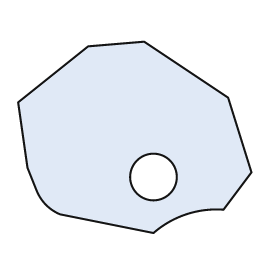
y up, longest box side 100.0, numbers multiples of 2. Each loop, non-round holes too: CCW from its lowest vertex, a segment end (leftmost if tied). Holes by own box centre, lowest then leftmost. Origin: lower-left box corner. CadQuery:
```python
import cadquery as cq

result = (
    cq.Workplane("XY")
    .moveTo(58.0, 0.0)
    .threePointArc((72.0, 8.0), (88.0, 10.0))
    .lineTo(100.0, 26.0)
    .lineTo(90.0, 58.0)
    .lineTo(54.0, 82.0)
    .lineTo(30.0, 80.0)
    .lineTo(0.0, 56.0)
    .lineTo(4.0, 28.0)
    .lineTo(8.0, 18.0)
    .threePointArc((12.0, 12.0), (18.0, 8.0))
    .close()
    .moveTo(58.0, 24.0)
    .circle(10.0)
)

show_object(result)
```